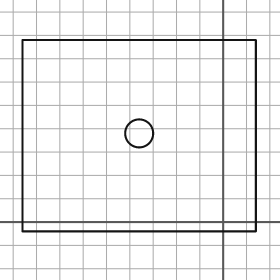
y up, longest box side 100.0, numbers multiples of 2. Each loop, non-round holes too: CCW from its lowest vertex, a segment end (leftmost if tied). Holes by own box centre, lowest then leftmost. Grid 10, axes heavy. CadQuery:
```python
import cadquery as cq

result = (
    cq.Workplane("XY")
    .moveTo(-86.0, -4.0)
    .lineTo(14.0, -4.0)
    .lineTo(14.0, 78.0)
    .lineTo(-86.0, 78.0)
    .close()
    .moveTo(-36.0, 38.0)
    .circle(6.0)
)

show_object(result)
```